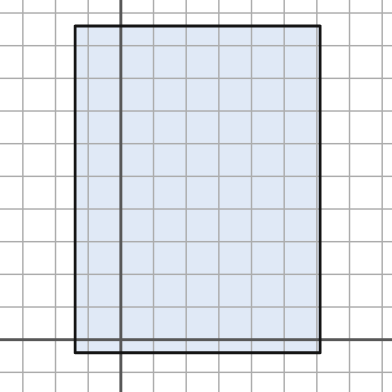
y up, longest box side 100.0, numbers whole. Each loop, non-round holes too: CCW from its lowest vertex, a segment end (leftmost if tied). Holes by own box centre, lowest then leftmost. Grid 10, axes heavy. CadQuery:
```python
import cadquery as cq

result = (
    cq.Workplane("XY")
    .moveTo(-14.0, -4.0)
    .lineTo(61.0, -4.0)
    .lineTo(61.0, 96.0)
    .lineTo(-14.0, 96.0)
    .close()
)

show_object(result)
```